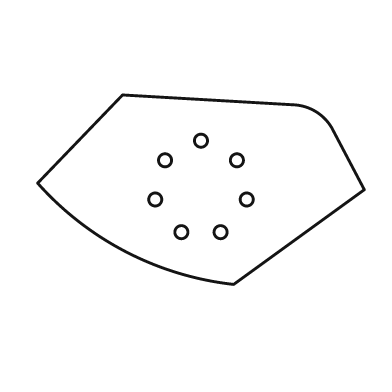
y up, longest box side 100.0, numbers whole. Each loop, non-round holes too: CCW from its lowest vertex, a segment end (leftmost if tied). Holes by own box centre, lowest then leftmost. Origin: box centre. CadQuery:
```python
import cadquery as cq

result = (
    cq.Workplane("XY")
    .moveTo(10.0, -29.0)
    .lineTo(50.0, 0.0)
    .lineTo(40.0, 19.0)
    .threePointArc((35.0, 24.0), (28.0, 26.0))
    .lineTo(-24.0, 29.0)
    .lineTo(-50.0, 2.0)
    .threePointArc((-23.0, -19.0), (10.0, -29.0))
    .close()
    .moveTo(-6.0, -13.0)
    .circle(2.0)
    .moveTo(6.0, -13.0)
    .circle(2.0)
    .moveTo(-14.0, -3.0)
    .circle(2.0)
    .moveTo(14.0, -3.0)
    .circle(2.0)
    .moveTo(-11.0, 9.0)
    .circle(2.0)
    .moveTo(11.0, 9.0)
    .circle(2.0)
    .moveTo(0.0, 15.0)
    .circle(2.0)
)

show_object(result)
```